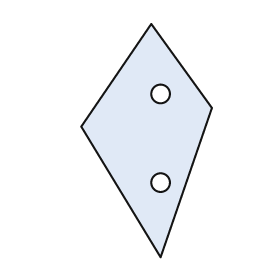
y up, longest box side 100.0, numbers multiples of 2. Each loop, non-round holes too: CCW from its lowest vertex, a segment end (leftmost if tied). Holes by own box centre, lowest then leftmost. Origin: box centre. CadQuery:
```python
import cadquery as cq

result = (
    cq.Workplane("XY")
    .moveTo(6.0, -50.0)
    .lineTo(28.0, 14.0)
    .lineTo(2.0, 50.0)
    .lineTo(-28.0, 6.0)
    .close()
    .moveTo(6.0, -18.0)
    .circle(4.0)
    .moveTo(6.0, 20.0)
    .circle(4.0)
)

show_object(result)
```